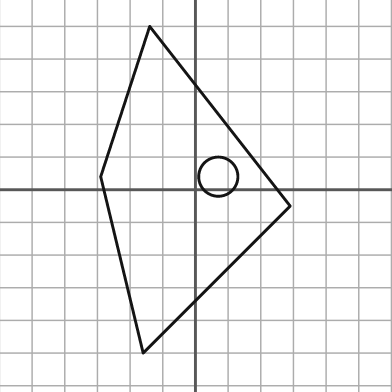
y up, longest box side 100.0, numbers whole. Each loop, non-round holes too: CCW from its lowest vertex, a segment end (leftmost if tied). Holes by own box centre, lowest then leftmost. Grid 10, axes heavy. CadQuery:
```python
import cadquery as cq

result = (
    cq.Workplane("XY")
    .moveTo(-16.0, -50.0)
    .lineTo(29.0, -5.0)
    .lineTo(-14.0, 50.0)
    .lineTo(-29.0, 4.0)
    .close()
    .moveTo(7.0, 4.0)
    .circle(6.0)
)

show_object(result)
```